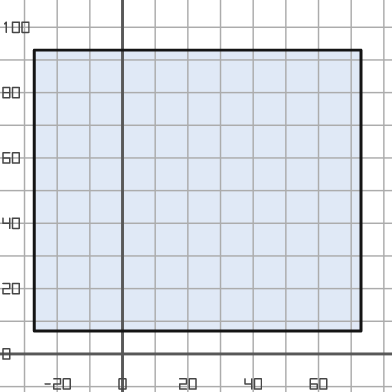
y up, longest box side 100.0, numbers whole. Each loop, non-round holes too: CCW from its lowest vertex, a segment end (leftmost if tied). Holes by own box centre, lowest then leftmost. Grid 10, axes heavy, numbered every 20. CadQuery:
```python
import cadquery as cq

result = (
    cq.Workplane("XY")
    .moveTo(-27.0, 7.0)
    .lineTo(73.0, 7.0)
    .lineTo(73.0, 93.0)
    .lineTo(-27.0, 93.0)
    .close()
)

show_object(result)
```